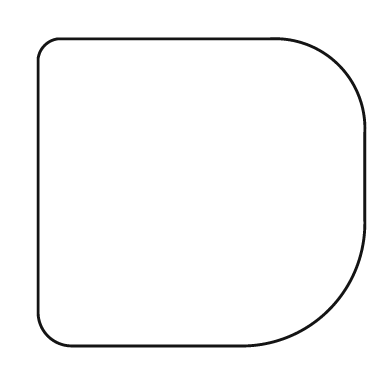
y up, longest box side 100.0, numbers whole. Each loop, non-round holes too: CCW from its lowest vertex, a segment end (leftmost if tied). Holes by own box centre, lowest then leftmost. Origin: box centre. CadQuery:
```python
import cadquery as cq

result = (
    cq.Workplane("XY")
    .moveTo(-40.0, -47.0)
    .lineTo(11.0, -47.0)
    .threePointArc((39.0, -36.0), (50.0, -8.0))
    .lineTo(50.0, 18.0)
    .threePointArc((42.0, 39.0), (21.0, 47.0))
    .lineTo(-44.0, 47.0)
    .threePointArc((-48.0, 45.0), (-50.0, 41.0))
    .lineTo(-50.0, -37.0)
    .threePointArc((-47.0, -44.0), (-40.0, -47.0))
    .close()
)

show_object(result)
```